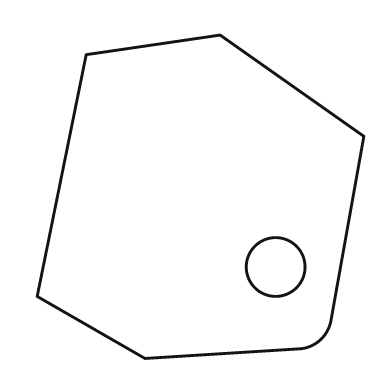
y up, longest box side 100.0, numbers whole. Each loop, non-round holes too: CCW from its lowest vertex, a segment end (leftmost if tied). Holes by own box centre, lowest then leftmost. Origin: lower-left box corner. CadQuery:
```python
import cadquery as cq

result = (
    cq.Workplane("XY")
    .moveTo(33.0, 0.0)
    .lineTo(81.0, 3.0)
    .threePointArc((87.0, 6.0), (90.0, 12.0))
    .lineTo(100.0, 68.0)
    .lineTo(56.0, 99.0)
    .lineTo(15.0, 93.0)
    .lineTo(0.0, 19.0)
    .close()
    .moveTo(73.0, 28.0)
    .circle(9.0)
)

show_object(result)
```